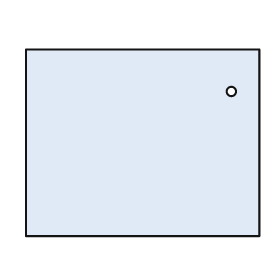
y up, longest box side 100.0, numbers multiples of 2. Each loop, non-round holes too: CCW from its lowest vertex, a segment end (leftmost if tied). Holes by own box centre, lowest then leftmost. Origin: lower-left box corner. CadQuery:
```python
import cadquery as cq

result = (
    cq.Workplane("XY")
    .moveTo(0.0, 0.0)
    .lineTo(100.0, 0.0)
    .lineTo(100.0, 80.0)
    .lineTo(0.0, 80.0)
    .close()
    .moveTo(88.0, 62.0)
    .circle(2.0)
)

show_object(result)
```